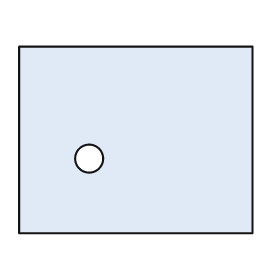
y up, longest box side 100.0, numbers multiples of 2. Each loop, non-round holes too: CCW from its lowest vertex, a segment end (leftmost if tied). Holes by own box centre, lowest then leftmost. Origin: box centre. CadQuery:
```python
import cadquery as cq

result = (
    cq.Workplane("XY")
    .moveTo(-50.0, -40.0)
    .lineTo(50.0, -40.0)
    .lineTo(50.0, 40.0)
    .lineTo(-50.0, 40.0)
    .close()
    .moveTo(-20.0, -8.0)
    .circle(6.0)
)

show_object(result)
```